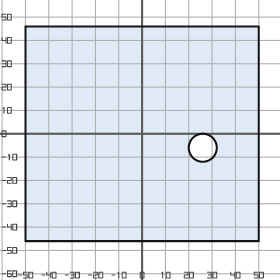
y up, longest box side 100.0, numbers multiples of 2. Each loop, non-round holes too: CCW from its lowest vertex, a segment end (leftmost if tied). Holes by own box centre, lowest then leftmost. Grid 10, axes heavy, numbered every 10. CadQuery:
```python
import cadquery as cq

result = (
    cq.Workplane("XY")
    .moveTo(-50.0, -46.0)
    .lineTo(50.0, -46.0)
    .lineTo(50.0, 46.0)
    .lineTo(-50.0, 46.0)
    .close()
    .moveTo(26.0, -6.0)
    .circle(6.0)
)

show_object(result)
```